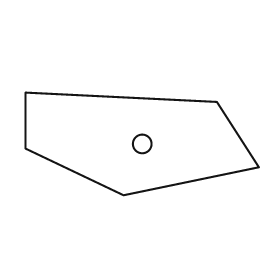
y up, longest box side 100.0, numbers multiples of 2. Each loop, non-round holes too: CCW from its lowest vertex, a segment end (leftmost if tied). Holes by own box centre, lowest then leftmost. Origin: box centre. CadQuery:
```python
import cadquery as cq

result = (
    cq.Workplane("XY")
    .moveTo(-8.0, -22.0)
    .lineTo(50.0, -10.0)
    .lineTo(32.0, 18.0)
    .lineTo(-50.0, 22.0)
    .lineTo(-50.0, -2.0)
    .close()
    .moveTo(0.0, 0.0)
    .circle(4.0)
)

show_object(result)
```